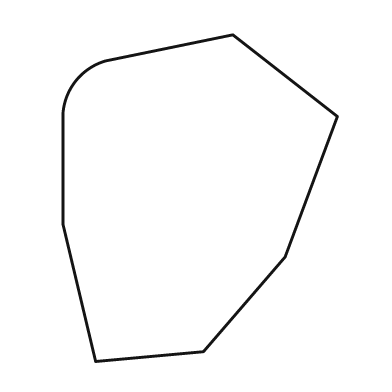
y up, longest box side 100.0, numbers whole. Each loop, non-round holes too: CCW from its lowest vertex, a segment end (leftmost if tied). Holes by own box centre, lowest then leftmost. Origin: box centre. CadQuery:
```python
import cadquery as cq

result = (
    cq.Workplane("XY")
    .moveTo(-32.0, -50.0)
    .lineTo(1.0, -47.0)
    .lineTo(26.0, -18.0)
    .lineTo(42.0, 25.0)
    .lineTo(10.0, 50.0)
    .lineTo(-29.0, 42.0)
    .threePointArc((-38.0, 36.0), (-42.0, 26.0))
    .lineTo(-42.0, -8.0)
    .close()
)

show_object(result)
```